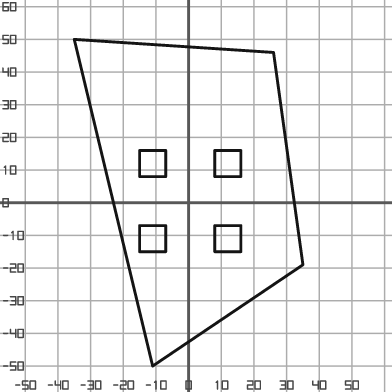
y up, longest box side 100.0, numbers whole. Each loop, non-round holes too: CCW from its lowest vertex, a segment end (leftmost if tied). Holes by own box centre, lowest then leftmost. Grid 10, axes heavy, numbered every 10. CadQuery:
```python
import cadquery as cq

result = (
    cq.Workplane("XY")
    .moveTo(-11.0, -50.0)
    .lineTo(35.0, -19.0)
    .lineTo(26.0, 46.0)
    .lineTo(-35.0, 50.0)
    .close()
    .moveTo(-15.0, -15.0)
    .lineTo(-7.0, -15.0)
    .lineTo(-7.0, -7.0)
    .lineTo(-15.0, -7.0)
    .close()
    .moveTo(8.0, -15.0)
    .lineTo(16.0, -15.0)
    .lineTo(16.0, -7.0)
    .lineTo(8.0, -7.0)
    .close()
    .moveTo(-15.0, 8.0)
    .lineTo(-7.0, 8.0)
    .lineTo(-7.0, 16.0)
    .lineTo(-15.0, 16.0)
    .close()
    .moveTo(8.0, 8.0)
    .lineTo(16.0, 8.0)
    .lineTo(16.0, 16.0)
    .lineTo(8.0, 16.0)
    .close()
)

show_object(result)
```